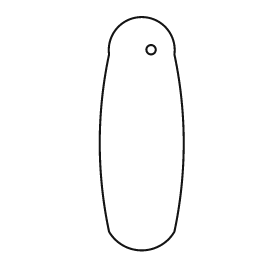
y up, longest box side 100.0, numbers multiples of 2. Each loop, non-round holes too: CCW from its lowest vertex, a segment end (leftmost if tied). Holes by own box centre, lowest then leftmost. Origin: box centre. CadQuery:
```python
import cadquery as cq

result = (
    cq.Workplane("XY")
    .moveTo(-14.0, -42.0)
    .threePointArc((0.0, -50.0), (14.0, -42.0))
    .threePointArc((18.0, -4.0), (14.0, 34.0))
    .threePointArc((0.0, 50.0), (-14.0, 34.0))
    .threePointArc((-18.0, -4.0), (-14.0, -42.0))
    .close()
    .moveTo(4.0, 36.0)
    .circle(2.0)
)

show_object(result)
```